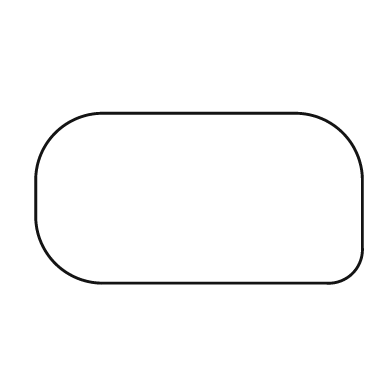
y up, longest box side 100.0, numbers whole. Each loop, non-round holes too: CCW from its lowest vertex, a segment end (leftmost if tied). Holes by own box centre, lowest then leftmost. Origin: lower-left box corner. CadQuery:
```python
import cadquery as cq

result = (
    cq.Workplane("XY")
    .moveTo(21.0, 0.0)
    .lineTo(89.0, 0.0)
    .threePointArc((97.0, 3.0), (100.0, 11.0))
    .lineTo(100.0, 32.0)
    .threePointArc((94.0, 46.0), (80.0, 52.0))
    .lineTo(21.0, 52.0)
    .threePointArc((6.0, 46.0), (0.0, 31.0))
    .lineTo(0.0, 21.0)
    .threePointArc((6.0, 6.0), (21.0, 0.0))
    .close()
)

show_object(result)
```